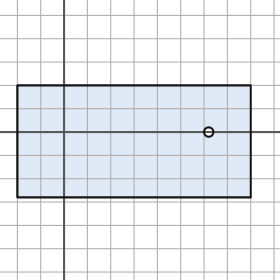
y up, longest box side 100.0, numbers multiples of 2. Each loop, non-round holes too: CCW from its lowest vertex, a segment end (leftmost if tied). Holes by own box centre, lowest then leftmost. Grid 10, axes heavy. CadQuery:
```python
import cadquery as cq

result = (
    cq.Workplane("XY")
    .moveTo(-20.0, -28.0)
    .lineTo(80.0, -28.0)
    .lineTo(80.0, 20.0)
    .lineTo(-20.0, 20.0)
    .close()
    .moveTo(62.0, 0.0)
    .circle(2.0)
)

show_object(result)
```